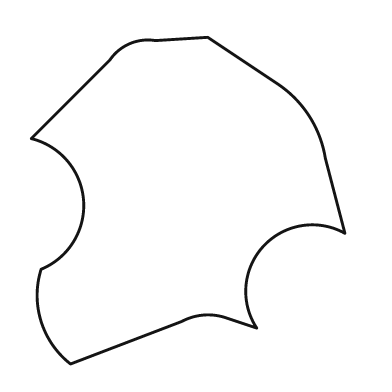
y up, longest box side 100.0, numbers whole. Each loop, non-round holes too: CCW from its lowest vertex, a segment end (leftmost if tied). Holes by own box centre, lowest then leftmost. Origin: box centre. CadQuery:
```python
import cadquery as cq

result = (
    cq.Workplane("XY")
    .moveTo(-36.0, -50.0)
    .lineTo(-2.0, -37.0)
    .threePointArc((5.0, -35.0), (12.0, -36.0))
    .lineTo(21.0, -39.0)
    .threePointArc((23.0, -14.0), (48.0, -10.0))
    .lineTo(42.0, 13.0)
    .threePointArc((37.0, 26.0), (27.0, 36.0))
    .lineTo(6.0, 50.0)
    .lineTo(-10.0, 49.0)
    .threePointArc((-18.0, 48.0), (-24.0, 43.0))
    .lineTo(-48.0, 19.0)
    .threePointArc((-32.0, 0.0), (-45.0, -21.0))
    .threePointArc((-45.0, -37.0), (-36.0, -50.0))
    .close()
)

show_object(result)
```